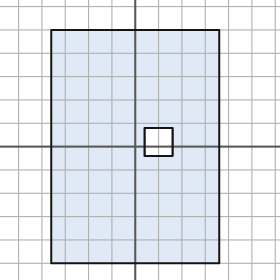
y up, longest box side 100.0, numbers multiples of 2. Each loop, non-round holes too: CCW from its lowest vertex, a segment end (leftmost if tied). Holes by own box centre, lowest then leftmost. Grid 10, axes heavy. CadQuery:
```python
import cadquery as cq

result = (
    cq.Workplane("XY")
    .moveTo(-36.0, -50.0)
    .lineTo(36.0, -50.0)
    .lineTo(36.0, 50.0)
    .lineTo(-36.0, 50.0)
    .close()
    .moveTo(4.0, -4.0)
    .lineTo(16.0, -4.0)
    .lineTo(16.0, 8.0)
    .lineTo(4.0, 8.0)
    .close()
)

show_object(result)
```